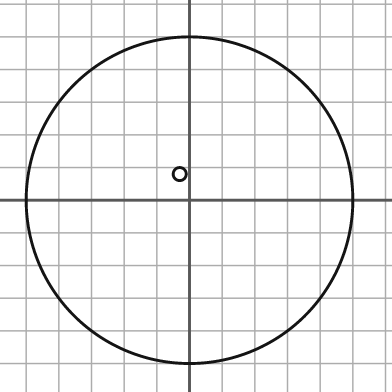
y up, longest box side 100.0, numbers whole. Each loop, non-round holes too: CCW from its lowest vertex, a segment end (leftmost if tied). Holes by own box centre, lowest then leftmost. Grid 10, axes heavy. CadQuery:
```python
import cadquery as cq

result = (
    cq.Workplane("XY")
    .moveTo(0.0, 0.0)
    .circle(50.0)
    .moveTo(-3.0, 8.0)
    .circle(2.0)
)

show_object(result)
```